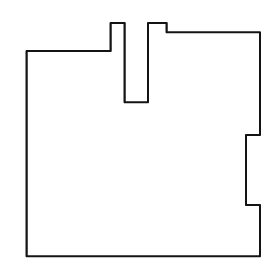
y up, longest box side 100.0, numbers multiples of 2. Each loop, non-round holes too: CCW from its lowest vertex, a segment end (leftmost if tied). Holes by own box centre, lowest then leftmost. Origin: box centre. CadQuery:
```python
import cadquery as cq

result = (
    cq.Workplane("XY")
    .moveTo(-50.0, -50.0)
    .lineTo(50.0, -50.0)
    .lineTo(50.0, -28.0)
    .lineTo(44.0, -28.0)
    .lineTo(44.0, 2.0)
    .lineTo(50.0, 2.0)
    .lineTo(50.0, 46.0)
    .lineTo(10.0, 46.0)
    .lineTo(10.0, 50.0)
    .lineTo(2.0, 50.0)
    .lineTo(2.0, 16.0)
    .lineTo(-8.0, 16.0)
    .lineTo(-8.0, 50.0)
    .lineTo(-14.0, 50.0)
    .lineTo(-14.0, 38.0)
    .lineTo(-50.0, 38.0)
    .close()
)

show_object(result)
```